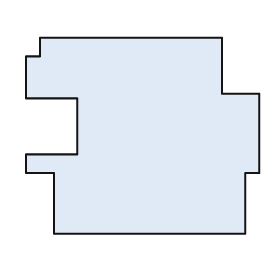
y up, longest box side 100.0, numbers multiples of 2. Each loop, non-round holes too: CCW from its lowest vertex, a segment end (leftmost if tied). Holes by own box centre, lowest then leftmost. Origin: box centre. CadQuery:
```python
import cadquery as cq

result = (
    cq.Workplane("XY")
    .moveTo(-38.0, -42.0)
    .lineTo(44.0, -42.0)
    .lineTo(44.0, -16.0)
    .lineTo(50.0, -16.0)
    .lineTo(50.0, 18.0)
    .lineTo(34.0, 18.0)
    .lineTo(34.0, 42.0)
    .lineTo(-44.0, 42.0)
    .lineTo(-44.0, 34.0)
    .lineTo(-50.0, 34.0)
    .lineTo(-50.0, 16.0)
    .lineTo(-28.0, 16.0)
    .lineTo(-28.0, -8.0)
    .lineTo(-50.0, -8.0)
    .lineTo(-50.0, -16.0)
    .lineTo(-38.0, -16.0)
    .close()
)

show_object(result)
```